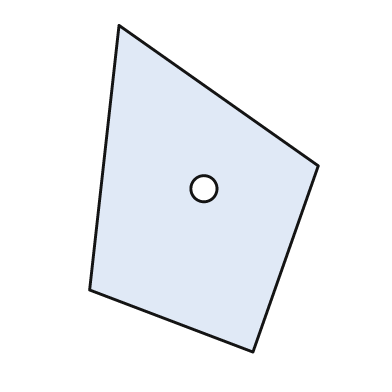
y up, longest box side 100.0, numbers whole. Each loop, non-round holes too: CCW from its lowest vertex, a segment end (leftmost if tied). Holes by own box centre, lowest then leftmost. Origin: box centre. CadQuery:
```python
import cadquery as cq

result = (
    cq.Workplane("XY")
    .moveTo(15.0, -50.0)
    .lineTo(35.0, 7.0)
    .lineTo(-26.0, 50.0)
    .lineTo(-35.0, -31.0)
    .close()
    .moveTo(0.0, 0.0)
    .circle(4.0)
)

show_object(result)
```